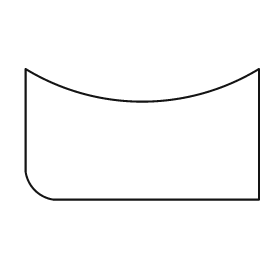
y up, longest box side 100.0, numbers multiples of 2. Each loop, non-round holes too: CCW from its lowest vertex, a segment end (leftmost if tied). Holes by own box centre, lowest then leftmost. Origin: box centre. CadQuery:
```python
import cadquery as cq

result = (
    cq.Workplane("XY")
    .moveTo(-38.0, -28.0)
    .lineTo(50.0, -28.0)
    .lineTo(50.0, 28.0)
    .threePointArc((0.0, 14.0), (-50.0, 28.0))
    .lineTo(-50.0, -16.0)
    .threePointArc((-46.0, -24.0), (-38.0, -28.0))
    .close()
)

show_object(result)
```